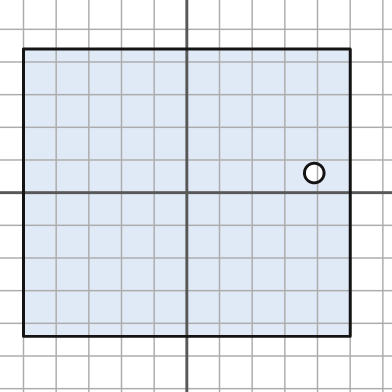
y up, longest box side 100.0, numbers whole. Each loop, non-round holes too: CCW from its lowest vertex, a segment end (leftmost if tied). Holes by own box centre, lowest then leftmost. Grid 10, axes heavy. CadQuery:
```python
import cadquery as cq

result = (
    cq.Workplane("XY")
    .moveTo(-50.0, -44.0)
    .lineTo(50.0, -44.0)
    .lineTo(50.0, 44.0)
    .lineTo(-50.0, 44.0)
    .close()
    .moveTo(39.0, 6.0)
    .circle(3.0)
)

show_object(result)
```